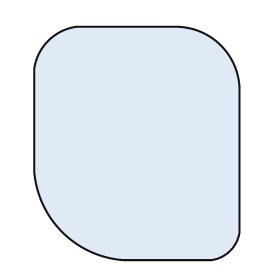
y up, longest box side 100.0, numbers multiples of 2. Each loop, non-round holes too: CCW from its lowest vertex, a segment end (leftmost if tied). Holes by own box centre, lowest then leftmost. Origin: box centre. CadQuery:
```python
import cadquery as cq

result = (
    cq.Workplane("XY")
    .moveTo(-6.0, -50.0)
    .lineTo(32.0, -50.0)
    .threePointArc((40.0, -46.0), (44.0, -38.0))
    .lineTo(44.0, 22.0)
    .threePointArc((36.0, 42.0), (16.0, 50.0))
    .lineTo(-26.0, 50.0)
    .threePointArc((-38.0, 44.0), (-44.0, 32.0))
    .lineTo(-44.0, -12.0)
    .threePointArc((-32.0, -38.0), (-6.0, -50.0))
    .close()
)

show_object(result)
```